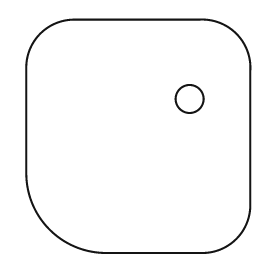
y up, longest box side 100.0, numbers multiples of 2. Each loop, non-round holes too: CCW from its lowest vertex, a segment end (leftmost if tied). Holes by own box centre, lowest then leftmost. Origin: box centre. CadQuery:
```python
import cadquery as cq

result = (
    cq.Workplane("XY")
    .moveTo(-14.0, -50.0)
    .lineTo(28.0, -50.0)
    .threePointArc((42.0, -44.0), (48.0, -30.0))
    .lineTo(48.0, 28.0)
    .threePointArc((42.0, 44.0), (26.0, 50.0))
    .lineTo(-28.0, 50.0)
    .threePointArc((-42.0, 44.0), (-48.0, 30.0))
    .lineTo(-48.0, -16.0)
    .threePointArc((-38.0, -40.0), (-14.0, -50.0))
    .close()
    .moveTo(22.0, 16.0)
    .circle(6.0)
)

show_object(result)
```